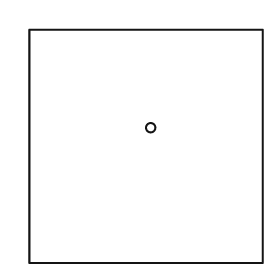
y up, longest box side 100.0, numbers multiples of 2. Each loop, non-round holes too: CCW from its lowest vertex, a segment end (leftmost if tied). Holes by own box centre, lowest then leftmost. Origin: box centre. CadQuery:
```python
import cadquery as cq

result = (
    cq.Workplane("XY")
    .moveTo(-50.0, -50.0)
    .lineTo(50.0, -50.0)
    .lineTo(50.0, 50.0)
    .lineTo(-50.0, 50.0)
    .close()
    .moveTo(2.0, 8.0)
    .circle(2.0)
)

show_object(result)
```